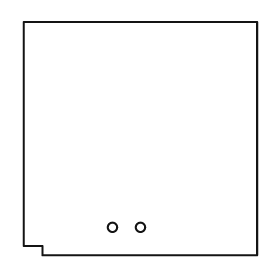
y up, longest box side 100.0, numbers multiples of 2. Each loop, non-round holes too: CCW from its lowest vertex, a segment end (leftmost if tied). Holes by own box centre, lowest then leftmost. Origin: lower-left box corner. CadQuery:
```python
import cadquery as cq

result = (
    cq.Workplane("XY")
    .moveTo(8.0, 0.0)
    .lineTo(100.0, 0.0)
    .lineTo(100.0, 100.0)
    .lineTo(0.0, 100.0)
    .lineTo(0.0, 4.0)
    .lineTo(8.0, 4.0)
    .close()
    .moveTo(38.0, 12.0)
    .circle(2.0)
    .moveTo(50.0, 12.0)
    .circle(2.0)
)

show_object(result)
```